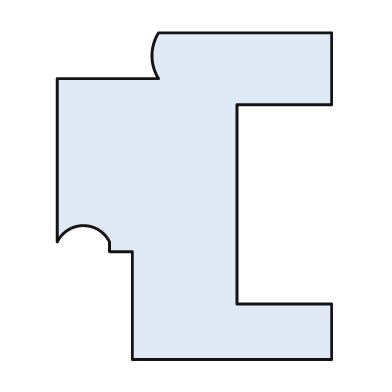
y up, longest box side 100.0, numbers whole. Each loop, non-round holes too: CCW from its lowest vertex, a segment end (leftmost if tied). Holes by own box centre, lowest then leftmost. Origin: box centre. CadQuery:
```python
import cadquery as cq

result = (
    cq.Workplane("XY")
    .moveTo(-19.0, -50.0)
    .lineTo(42.0, -50.0)
    .lineTo(42.0, -33.0)
    .lineTo(13.0, -33.0)
    .lineTo(13.0, 28.0)
    .lineTo(42.0, 28.0)
    .lineTo(42.0, 50.0)
    .lineTo(-11.0, 50.0)
    .threePointArc((-13.0, 43.0), (-11.0, 36.0))
    .lineTo(-42.0, 36.0)
    .lineTo(-42.0, -14.0)
    .threePointArc((-34.0, -9.0), (-26.0, -14.0))
    .lineTo(-26.0, -17.0)
    .lineTo(-19.0, -17.0)
    .close()
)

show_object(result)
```